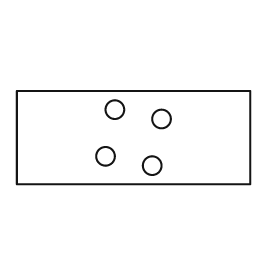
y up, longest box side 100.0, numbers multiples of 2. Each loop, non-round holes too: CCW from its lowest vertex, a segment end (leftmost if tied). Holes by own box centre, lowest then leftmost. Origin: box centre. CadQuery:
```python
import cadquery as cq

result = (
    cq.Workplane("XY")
    .moveTo(-50.0, -20.0)
    .lineTo(50.0, -20.0)
    .lineTo(50.0, 20.0)
    .lineTo(-50.0, 20.0)
    .close()
    .moveTo(8.0, -12.0)
    .circle(4.0)
    .moveTo(-12.0, -8.0)
    .circle(4.0)
    .moveTo(12.0, 8.0)
    .circle(4.0)
    .moveTo(-8.0, 12.0)
    .circle(4.0)
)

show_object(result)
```